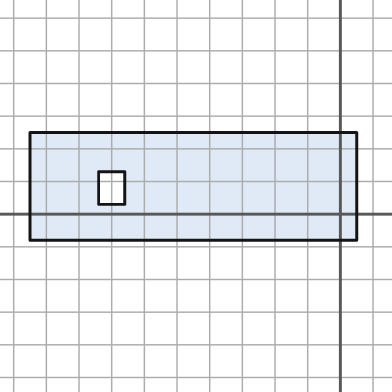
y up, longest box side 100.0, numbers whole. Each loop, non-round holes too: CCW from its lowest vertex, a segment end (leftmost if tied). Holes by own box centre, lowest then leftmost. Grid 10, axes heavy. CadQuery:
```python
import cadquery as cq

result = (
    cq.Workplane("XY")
    .moveTo(-95.0, -8.0)
    .lineTo(5.0, -8.0)
    .lineTo(5.0, 25.0)
    .lineTo(-95.0, 25.0)
    .close()
    .moveTo(-74.0, 3.0)
    .lineTo(-66.0, 3.0)
    .lineTo(-66.0, 13.0)
    .lineTo(-74.0, 13.0)
    .close()
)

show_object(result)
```